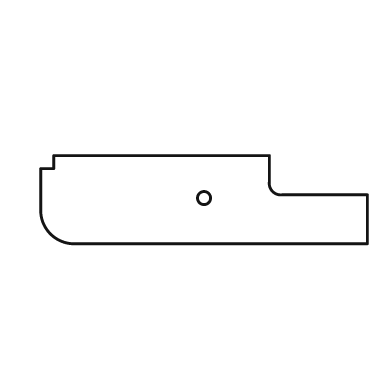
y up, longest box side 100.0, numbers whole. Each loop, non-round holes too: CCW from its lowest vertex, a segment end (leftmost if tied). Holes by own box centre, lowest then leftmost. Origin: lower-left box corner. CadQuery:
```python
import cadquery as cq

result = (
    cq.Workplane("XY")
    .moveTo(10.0, 0.0)
    .lineTo(100.0, 0.0)
    .lineTo(100.0, 15.0)
    .lineTo(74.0, 15.0)
    .threePointArc((71.0, 16.0), (70.0, 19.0))
    .lineTo(70.0, 27.0)
    .lineTo(4.0, 27.0)
    .lineTo(4.0, 23.0)
    .lineTo(0.0, 23.0)
    .lineTo(0.0, 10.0)
    .threePointArc((3.0, 3.0), (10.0, 0.0))
    .close()
    .moveTo(50.0, 14.0)
    .circle(2.0)
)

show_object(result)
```